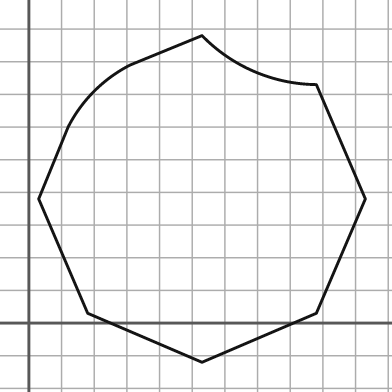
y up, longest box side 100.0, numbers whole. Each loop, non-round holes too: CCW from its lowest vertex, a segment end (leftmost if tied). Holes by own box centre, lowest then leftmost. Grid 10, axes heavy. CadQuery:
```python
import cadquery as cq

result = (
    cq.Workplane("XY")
    .moveTo(53.0, -12.0)
    .lineTo(88.0, 3.0)
    .lineTo(103.0, 38.0)
    .lineTo(88.0, 73.0)
    .threePointArc((69.0, 77.0), (53.0, 88.0))
    .lineTo(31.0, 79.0)
    .threePointArc((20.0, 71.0), (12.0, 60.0))
    .lineTo(3.0, 38.0)
    .lineTo(18.0, 3.0)
    .close()
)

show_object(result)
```